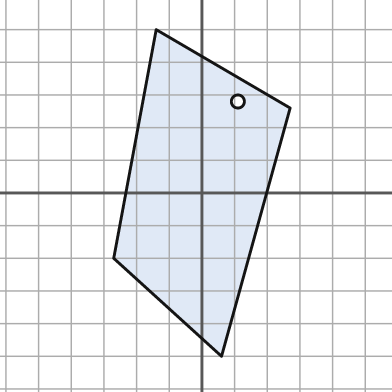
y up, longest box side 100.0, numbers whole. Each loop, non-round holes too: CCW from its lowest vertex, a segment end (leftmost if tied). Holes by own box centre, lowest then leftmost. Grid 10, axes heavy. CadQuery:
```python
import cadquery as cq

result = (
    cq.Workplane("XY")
    .moveTo(6.0, -50.0)
    .lineTo(27.0, 26.0)
    .lineTo(-14.0, 50.0)
    .lineTo(-27.0, -20.0)
    .close()
    .moveTo(11.0, 28.0)
    .circle(2.0)
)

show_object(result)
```